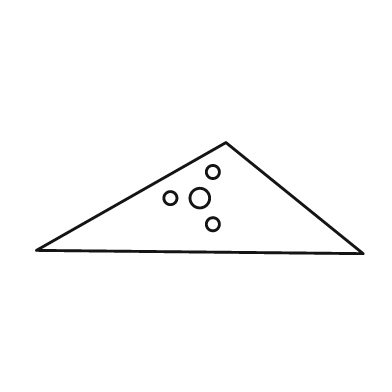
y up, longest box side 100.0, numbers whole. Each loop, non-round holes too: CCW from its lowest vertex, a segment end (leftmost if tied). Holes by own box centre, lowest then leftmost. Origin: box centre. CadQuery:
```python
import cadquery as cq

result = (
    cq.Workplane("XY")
    .moveTo(50.0, -17.0)
    .lineTo(8.0, 17.0)
    .lineTo(-50.0, -16.0)
    .close()
    .moveTo(4.0, -8.0)
    .circle(2.0)
    .moveTo(-9.0, 0.0)
    .circle(2.0)
    .moveTo(0.0, 0.0)
    .circle(3.0)
    .moveTo(4.0, 8.0)
    .circle(2.0)
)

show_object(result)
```